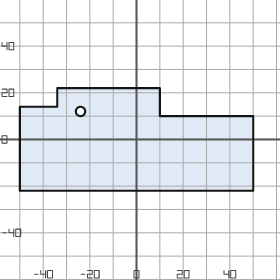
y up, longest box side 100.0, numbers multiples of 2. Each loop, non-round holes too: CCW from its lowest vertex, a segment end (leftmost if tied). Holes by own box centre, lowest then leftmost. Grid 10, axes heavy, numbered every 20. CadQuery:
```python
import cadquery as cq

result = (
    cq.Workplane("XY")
    .moveTo(-50.0, -22.0)
    .lineTo(50.0, -22.0)
    .lineTo(50.0, 10.0)
    .lineTo(10.0, 10.0)
    .lineTo(10.0, 22.0)
    .lineTo(-34.0, 22.0)
    .lineTo(-34.0, 14.0)
    .lineTo(-50.0, 14.0)
    .close()
    .moveTo(-24.0, 12.0)
    .circle(2.0)
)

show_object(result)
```